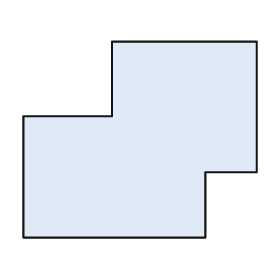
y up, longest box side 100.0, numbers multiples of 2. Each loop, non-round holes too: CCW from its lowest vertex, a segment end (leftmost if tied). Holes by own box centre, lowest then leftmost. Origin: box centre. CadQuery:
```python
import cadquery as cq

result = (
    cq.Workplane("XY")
    .moveTo(-50.0, -42.0)
    .lineTo(28.0, -42.0)
    .lineTo(28.0, -14.0)
    .lineTo(50.0, -14.0)
    .lineTo(50.0, 42.0)
    .lineTo(-12.0, 42.0)
    .lineTo(-12.0, 10.0)
    .lineTo(-50.0, 10.0)
    .close()
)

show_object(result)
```